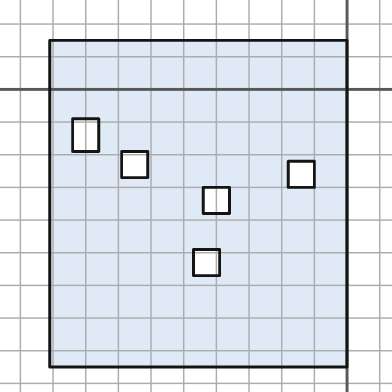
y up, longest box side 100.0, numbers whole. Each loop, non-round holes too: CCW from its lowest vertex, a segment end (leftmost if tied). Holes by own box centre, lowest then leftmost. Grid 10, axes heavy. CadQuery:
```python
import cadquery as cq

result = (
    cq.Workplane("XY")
    .moveTo(-91.0, -85.0)
    .lineTo(0.0, -85.0)
    .lineTo(0.0, 15.0)
    .lineTo(-91.0, 15.0)
    .close()
    .moveTo(-47.0, -57.0)
    .lineTo(-39.0, -57.0)
    .lineTo(-39.0, -49.0)
    .lineTo(-47.0, -49.0)
    .close()
    .moveTo(-44.0, -38.0)
    .lineTo(-36.0, -38.0)
    .lineTo(-36.0, -30.0)
    .lineTo(-44.0, -30.0)
    .close()
    .moveTo(-18.0, -30.0)
    .lineTo(-10.0, -30.0)
    .lineTo(-10.0, -22.0)
    .lineTo(-18.0, -22.0)
    .close()
    .moveTo(-69.0, -27.0)
    .lineTo(-61.0, -27.0)
    .lineTo(-61.0, -19.0)
    .lineTo(-69.0, -19.0)
    .close()
    .moveTo(-84.0, -19.0)
    .lineTo(-76.0, -19.0)
    .lineTo(-76.0, -9.0)
    .lineTo(-84.0, -9.0)
    .close()
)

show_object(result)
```